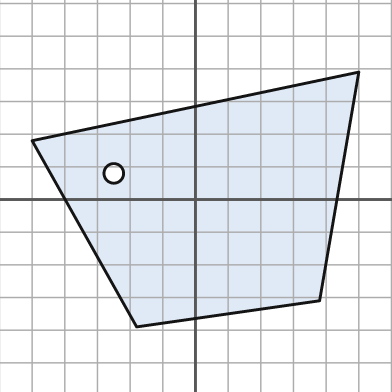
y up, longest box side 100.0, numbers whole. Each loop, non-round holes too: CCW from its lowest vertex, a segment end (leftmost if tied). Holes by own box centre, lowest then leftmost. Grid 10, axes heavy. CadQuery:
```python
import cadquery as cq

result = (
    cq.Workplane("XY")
    .moveTo(-18.0, -39.0)
    .lineTo(38.0, -31.0)
    .lineTo(50.0, 39.0)
    .lineTo(-50.0, 18.0)
    .close()
    .moveTo(-25.0, 8.0)
    .circle(3.0)
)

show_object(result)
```